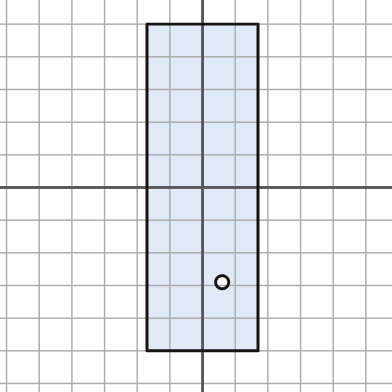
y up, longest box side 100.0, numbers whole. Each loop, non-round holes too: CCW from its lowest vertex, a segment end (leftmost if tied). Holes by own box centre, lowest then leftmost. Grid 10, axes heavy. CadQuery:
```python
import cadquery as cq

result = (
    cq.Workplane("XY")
    .moveTo(-17.0, -50.0)
    .lineTo(17.0, -50.0)
    .lineTo(17.0, 50.0)
    .lineTo(-17.0, 50.0)
    .close()
    .moveTo(6.0, -29.0)
    .circle(2.0)
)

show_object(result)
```